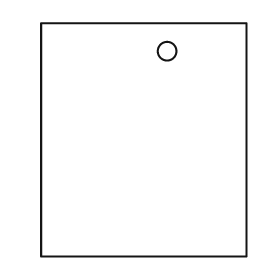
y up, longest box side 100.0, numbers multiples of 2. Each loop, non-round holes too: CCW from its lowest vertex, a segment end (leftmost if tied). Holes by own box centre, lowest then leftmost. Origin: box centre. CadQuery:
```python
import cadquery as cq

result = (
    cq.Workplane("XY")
    .moveTo(-44.0, -50.0)
    .lineTo(44.0, -50.0)
    .lineTo(44.0, 50.0)
    .lineTo(-44.0, 50.0)
    .close()
    .moveTo(10.0, 38.0)
    .circle(4.0)
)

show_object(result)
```